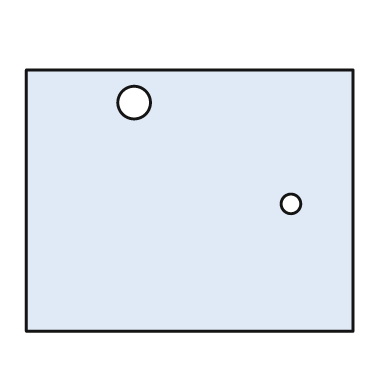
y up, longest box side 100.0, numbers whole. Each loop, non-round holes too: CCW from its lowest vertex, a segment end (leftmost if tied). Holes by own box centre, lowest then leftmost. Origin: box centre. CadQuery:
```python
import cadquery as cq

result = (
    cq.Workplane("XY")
    .moveTo(-50.0, -40.0)
    .lineTo(50.0, -40.0)
    .lineTo(50.0, 40.0)
    .lineTo(-50.0, 40.0)
    .close()
    .moveTo(31.0, -1.0)
    .circle(3.0)
    .moveTo(-17.0, 30.0)
    .circle(5.0)
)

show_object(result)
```